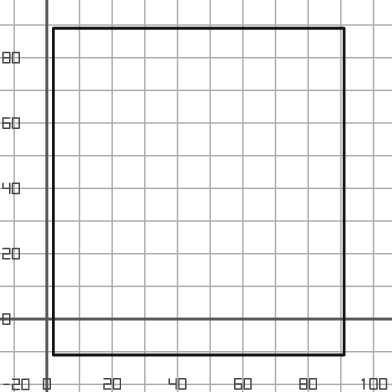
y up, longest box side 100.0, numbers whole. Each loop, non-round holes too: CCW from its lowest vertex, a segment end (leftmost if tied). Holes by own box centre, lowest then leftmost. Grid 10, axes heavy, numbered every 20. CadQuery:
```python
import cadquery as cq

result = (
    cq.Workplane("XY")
    .moveTo(2.0, -11.0)
    .lineTo(91.0, -11.0)
    .lineTo(91.0, 89.0)
    .lineTo(2.0, 89.0)
    .close()
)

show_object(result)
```